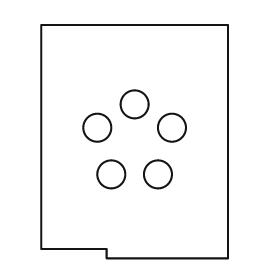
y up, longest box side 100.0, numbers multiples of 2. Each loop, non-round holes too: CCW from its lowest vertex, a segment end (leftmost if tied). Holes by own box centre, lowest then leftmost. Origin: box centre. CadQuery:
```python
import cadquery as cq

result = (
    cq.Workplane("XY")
    .moveTo(-12.0, -50.0)
    .lineTo(40.0, -50.0)
    .lineTo(40.0, 50.0)
    .lineTo(-40.0, 50.0)
    .lineTo(-40.0, -46.0)
    .lineTo(-12.0, -46.0)
    .close()
    .moveTo(-10.0, -14.0)
    .circle(6.0)
    .moveTo(10.0, -14.0)
    .circle(6.0)
    .moveTo(-16.0, 6.0)
    .circle(6.0)
    .moveTo(16.0, 6.0)
    .circle(6.0)
    .moveTo(0.0, 16.0)
    .circle(6.0)
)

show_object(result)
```